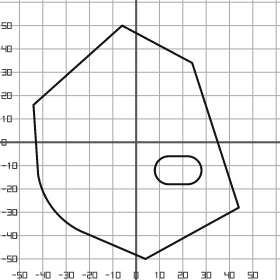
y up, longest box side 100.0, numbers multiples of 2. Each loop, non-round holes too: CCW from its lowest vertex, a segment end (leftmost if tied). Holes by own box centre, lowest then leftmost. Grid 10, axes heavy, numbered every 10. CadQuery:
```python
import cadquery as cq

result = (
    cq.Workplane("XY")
    .moveTo(4.0, -50.0)
    .lineTo(44.0, -28.0)
    .lineTo(24.0, 34.0)
    .lineTo(-6.0, 50.0)
    .lineTo(-44.0, 16.0)
    .lineTo(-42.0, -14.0)
    .threePointArc((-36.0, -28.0), (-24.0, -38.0))
    .close()
    .moveTo(14.0, -18.0)
    .lineTo(22.0, -18.0)
    .threePointArc((28.0, -12.0), (22.0, -6.0))
    .lineTo(14.0, -6.0)
    .threePointArc((8.0, -12.0), (14.0, -18.0))
    .close()
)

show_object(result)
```